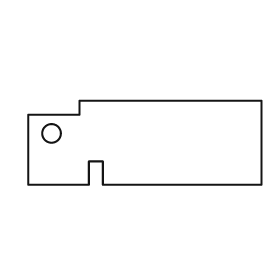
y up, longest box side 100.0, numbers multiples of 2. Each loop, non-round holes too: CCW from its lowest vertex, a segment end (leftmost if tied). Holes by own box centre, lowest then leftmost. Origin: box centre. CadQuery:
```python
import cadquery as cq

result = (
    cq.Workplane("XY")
    .moveTo(-50.0, -18.0)
    .lineTo(-24.0, -18.0)
    .lineTo(-24.0, -8.0)
    .lineTo(-18.0, -8.0)
    .lineTo(-18.0, -18.0)
    .lineTo(50.0, -18.0)
    .lineTo(50.0, 18.0)
    .lineTo(-28.0, 18.0)
    .lineTo(-28.0, 12.0)
    .lineTo(-50.0, 12.0)
    .close()
    .moveTo(-40.0, 4.0)
    .circle(4.0)
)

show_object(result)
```